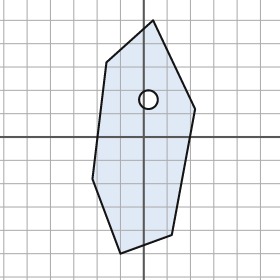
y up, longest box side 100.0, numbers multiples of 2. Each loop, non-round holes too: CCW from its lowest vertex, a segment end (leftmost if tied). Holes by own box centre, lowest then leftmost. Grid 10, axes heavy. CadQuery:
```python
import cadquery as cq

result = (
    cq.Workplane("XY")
    .moveTo(-10.0, -50.0)
    .lineTo(12.0, -42.0)
    .lineTo(22.0, 12.0)
    .lineTo(4.0, 50.0)
    .lineTo(-16.0, 32.0)
    .lineTo(-22.0, -18.0)
    .close()
    .moveTo(2.0, 16.0)
    .circle(4.0)
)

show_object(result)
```